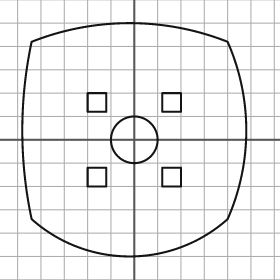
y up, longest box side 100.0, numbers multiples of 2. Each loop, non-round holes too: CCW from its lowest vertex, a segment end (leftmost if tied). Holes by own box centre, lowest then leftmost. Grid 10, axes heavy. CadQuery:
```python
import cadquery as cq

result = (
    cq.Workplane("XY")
    .moveTo(-44.0, -34.0)
    .threePointArc((-2.0, -50.0), (40.0, -34.0))
    .threePointArc((48.0, 4.0), (40.0, 42.0))
    .threePointArc((-2.0, 50.0), (-44.0, 42.0))
    .threePointArc((-48.0, 4.0), (-44.0, -34.0))
    .close()
    .moveTo(-20.0, -20.0)
    .lineTo(-12.0, -20.0)
    .lineTo(-12.0, -12.0)
    .lineTo(-20.0, -12.0)
    .close()
    .moveTo(12.0, -20.0)
    .lineTo(20.0, -20.0)
    .lineTo(20.0, -12.0)
    .lineTo(12.0, -12.0)
    .close()
    .moveTo(0.0, 0.0)
    .circle(10.0)
    .moveTo(-20.0, 12.0)
    .lineTo(-12.0, 12.0)
    .lineTo(-12.0, 20.0)
    .lineTo(-20.0, 20.0)
    .close()
    .moveTo(12.0, 12.0)
    .lineTo(20.0, 12.0)
    .lineTo(20.0, 20.0)
    .lineTo(12.0, 20.0)
    .close()
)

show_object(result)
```